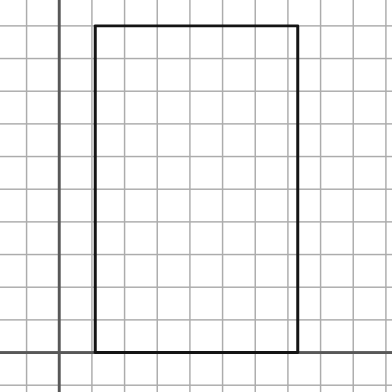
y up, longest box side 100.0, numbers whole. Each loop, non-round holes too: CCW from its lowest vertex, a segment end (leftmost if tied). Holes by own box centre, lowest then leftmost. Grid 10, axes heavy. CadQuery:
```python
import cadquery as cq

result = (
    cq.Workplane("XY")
    .moveTo(11.0, 0.0)
    .lineTo(73.0, 0.0)
    .lineTo(73.0, 100.0)
    .lineTo(11.0, 100.0)
    .close()
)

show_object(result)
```